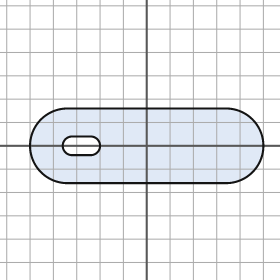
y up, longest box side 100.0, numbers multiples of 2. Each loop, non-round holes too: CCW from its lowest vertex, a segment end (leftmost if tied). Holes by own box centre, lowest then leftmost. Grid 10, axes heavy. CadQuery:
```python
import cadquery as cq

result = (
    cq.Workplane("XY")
    .moveTo(-34.0, -16.0)
    .lineTo(34.0, -16.0)
    .threePointArc((50.0, 0.0), (34.0, 16.0))
    .lineTo(-34.0, 16.0)
    .threePointArc((-50.0, 0.0), (-34.0, -16.0))
    .close()
    .moveTo(-32.0, -4.0)
    .lineTo(-24.0, -4.0)
    .threePointArc((-20.0, 0.0), (-24.0, 4.0))
    .lineTo(-32.0, 4.0)
    .threePointArc((-36.0, 0.0), (-32.0, -4.0))
    .close()
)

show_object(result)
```